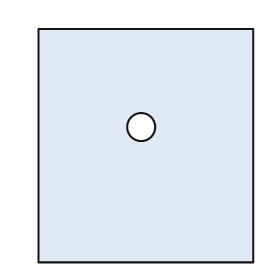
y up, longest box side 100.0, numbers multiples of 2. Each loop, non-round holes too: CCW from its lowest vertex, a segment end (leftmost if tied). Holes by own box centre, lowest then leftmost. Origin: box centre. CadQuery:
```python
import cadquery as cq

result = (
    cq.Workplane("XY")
    .moveTo(-46.0, -50.0)
    .lineTo(46.0, -50.0)
    .lineTo(46.0, 50.0)
    .lineTo(-46.0, 50.0)
    .close()
    .moveTo(-2.0, 8.0)
    .circle(6.0)
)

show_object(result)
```